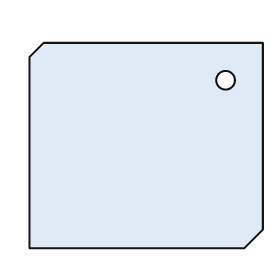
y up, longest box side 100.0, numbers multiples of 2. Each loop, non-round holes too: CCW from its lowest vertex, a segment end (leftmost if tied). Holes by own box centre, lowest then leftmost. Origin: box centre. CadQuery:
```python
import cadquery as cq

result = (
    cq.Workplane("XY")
    .moveTo(-50.0, -44.0)
    .lineTo(42.0, -44.0)
    .lineTo(50.0, -36.0)
    .lineTo(50.0, 44.0)
    .lineTo(-44.0, 44.0)
    .lineTo(-50.0, 38.0)
    .close()
    .moveTo(34.0, 28.0)
    .circle(4.0)
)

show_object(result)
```